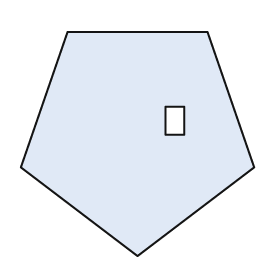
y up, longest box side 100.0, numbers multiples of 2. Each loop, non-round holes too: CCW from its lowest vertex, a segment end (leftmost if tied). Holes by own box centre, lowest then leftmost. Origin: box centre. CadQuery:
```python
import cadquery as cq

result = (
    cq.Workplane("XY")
    .moveTo(0.0, -48.0)
    .lineTo(50.0, -10.0)
    .lineTo(30.0, 48.0)
    .lineTo(-30.0, 48.0)
    .lineTo(-50.0, -10.0)
    .close()
    .moveTo(12.0, 4.0)
    .lineTo(20.0, 4.0)
    .lineTo(20.0, 16.0)
    .lineTo(12.0, 16.0)
    .close()
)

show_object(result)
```